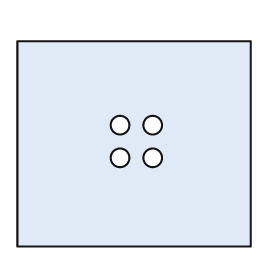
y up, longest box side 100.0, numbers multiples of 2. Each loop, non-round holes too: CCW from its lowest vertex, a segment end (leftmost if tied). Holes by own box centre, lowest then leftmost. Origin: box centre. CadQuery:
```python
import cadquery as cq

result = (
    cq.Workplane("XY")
    .moveTo(-50.0, -44.0)
    .lineTo(50.0, -44.0)
    .lineTo(50.0, 44.0)
    .lineTo(-50.0, 44.0)
    .close()
    .moveTo(-6.0, -6.0)
    .circle(4.0)
    .moveTo(8.0, -6.0)
    .circle(4.0)
    .moveTo(-6.0, 8.0)
    .circle(4.0)
    .moveTo(8.0, 8.0)
    .circle(4.0)
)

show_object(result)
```